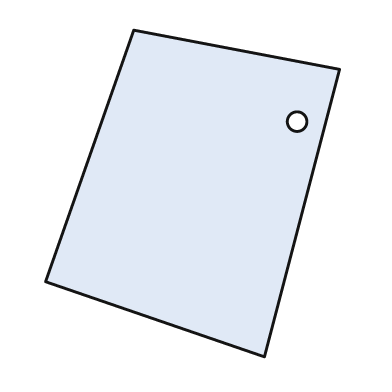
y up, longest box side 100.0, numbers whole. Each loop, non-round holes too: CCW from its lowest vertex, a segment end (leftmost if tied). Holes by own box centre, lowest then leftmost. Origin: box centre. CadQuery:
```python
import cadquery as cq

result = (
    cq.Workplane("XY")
    .moveTo(22.0, -50.0)
    .lineTo(45.0, 38.0)
    .lineTo(-18.0, 50.0)
    .lineTo(-45.0, -27.0)
    .close()
    .moveTo(32.0, 22.0)
    .circle(3.0)
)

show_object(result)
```